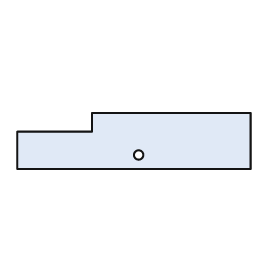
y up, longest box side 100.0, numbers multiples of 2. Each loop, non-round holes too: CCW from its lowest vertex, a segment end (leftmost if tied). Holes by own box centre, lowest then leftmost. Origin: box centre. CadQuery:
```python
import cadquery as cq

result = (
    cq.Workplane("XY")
    .moveTo(-50.0, -12.0)
    .lineTo(50.0, -12.0)
    .lineTo(50.0, 12.0)
    .lineTo(-18.0, 12.0)
    .lineTo(-18.0, 4.0)
    .lineTo(-50.0, 4.0)
    .close()
    .moveTo(2.0, -6.0)
    .circle(2.0)
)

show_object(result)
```